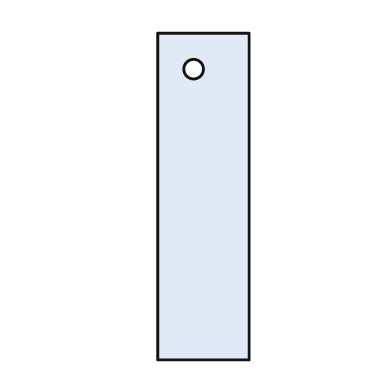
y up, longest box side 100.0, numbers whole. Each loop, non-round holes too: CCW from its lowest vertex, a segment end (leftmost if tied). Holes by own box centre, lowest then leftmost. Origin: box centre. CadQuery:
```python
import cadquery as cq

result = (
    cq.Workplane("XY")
    .moveTo(-14.0, -50.0)
    .lineTo(14.0, -50.0)
    .lineTo(14.0, 50.0)
    .lineTo(-14.0, 50.0)
    .close()
    .moveTo(-3.0, 39.0)
    .circle(3.0)
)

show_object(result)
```